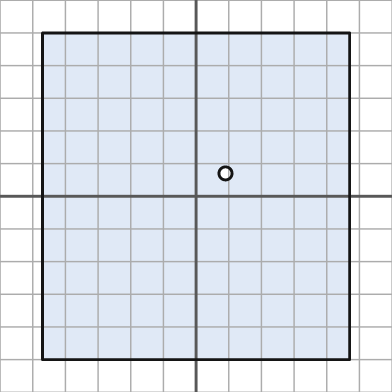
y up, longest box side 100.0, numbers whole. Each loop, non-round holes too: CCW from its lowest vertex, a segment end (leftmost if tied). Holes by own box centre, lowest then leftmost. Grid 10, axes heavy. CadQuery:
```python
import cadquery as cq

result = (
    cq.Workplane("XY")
    .moveTo(-47.0, -50.0)
    .lineTo(47.0, -50.0)
    .lineTo(47.0, 50.0)
    .lineTo(-47.0, 50.0)
    .close()
    .moveTo(9.0, 7.0)
    .circle(2.0)
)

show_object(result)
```